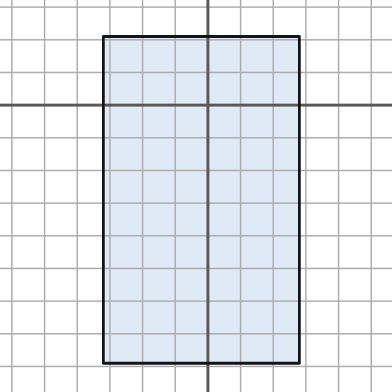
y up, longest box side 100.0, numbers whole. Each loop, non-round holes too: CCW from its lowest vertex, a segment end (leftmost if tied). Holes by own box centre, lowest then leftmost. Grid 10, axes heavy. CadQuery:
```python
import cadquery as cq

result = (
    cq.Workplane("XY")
    .moveTo(-32.0, -79.0)
    .lineTo(28.0, -79.0)
    .lineTo(28.0, 21.0)
    .lineTo(-32.0, 21.0)
    .close()
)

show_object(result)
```